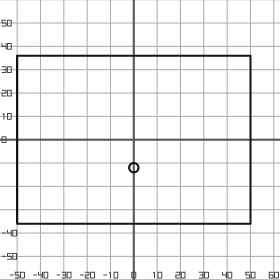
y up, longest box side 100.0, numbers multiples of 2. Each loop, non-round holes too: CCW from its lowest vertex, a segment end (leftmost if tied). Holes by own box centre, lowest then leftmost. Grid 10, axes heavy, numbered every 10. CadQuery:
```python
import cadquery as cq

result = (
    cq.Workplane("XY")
    .moveTo(-50.0, -36.0)
    .lineTo(50.0, -36.0)
    .lineTo(50.0, 36.0)
    .lineTo(-50.0, 36.0)
    .close()
    .moveTo(0.0, -12.0)
    .circle(2.0)
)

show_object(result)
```